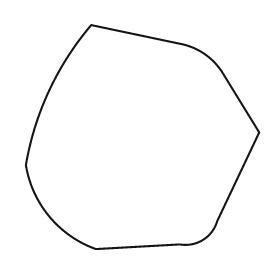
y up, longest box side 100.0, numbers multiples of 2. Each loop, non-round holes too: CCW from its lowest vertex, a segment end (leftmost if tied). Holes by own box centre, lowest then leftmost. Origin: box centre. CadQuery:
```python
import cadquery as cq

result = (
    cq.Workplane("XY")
    .moveTo(-20.0, -48.0)
    .lineTo(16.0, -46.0)
    .threePointArc((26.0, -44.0), (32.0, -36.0))
    .lineTo(50.0, 2.0)
    .lineTo(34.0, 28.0)
    .threePointArc((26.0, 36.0), (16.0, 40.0))
    .lineTo(-22.0, 48.0)
    .threePointArc((-40.0, 20.0), (-50.0, -12.0))
    .threePointArc((-40.0, -34.0), (-20.0, -48.0))
    .close()
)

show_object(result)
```